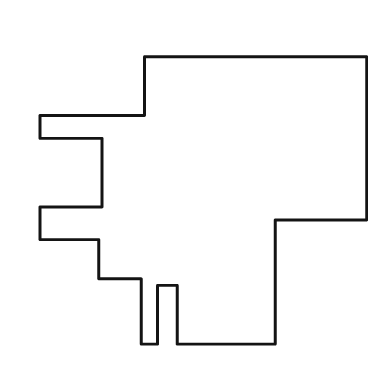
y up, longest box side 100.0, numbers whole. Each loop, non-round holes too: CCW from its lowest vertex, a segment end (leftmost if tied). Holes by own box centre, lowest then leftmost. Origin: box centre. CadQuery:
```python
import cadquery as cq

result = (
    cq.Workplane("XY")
    .moveTo(-19.0, -44.0)
    .lineTo(-14.0, -44.0)
    .lineTo(-14.0, -26.0)
    .lineTo(-8.0, -26.0)
    .lineTo(-8.0, -44.0)
    .lineTo(22.0, -44.0)
    .lineTo(22.0, -6.0)
    .lineTo(50.0, -6.0)
    .lineTo(50.0, 44.0)
    .lineTo(-18.0, 44.0)
    .lineTo(-18.0, 26.0)
    .lineTo(-50.0, 26.0)
    .lineTo(-50.0, 19.0)
    .lineTo(-31.0, 19.0)
    .lineTo(-31.0, -2.0)
    .lineTo(-50.0, -2.0)
    .lineTo(-50.0, -12.0)
    .lineTo(-32.0, -12.0)
    .lineTo(-32.0, -24.0)
    .lineTo(-19.0, -24.0)
    .close()
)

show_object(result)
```